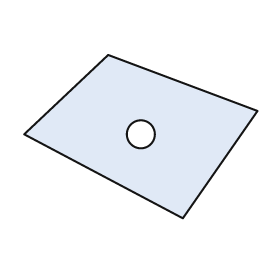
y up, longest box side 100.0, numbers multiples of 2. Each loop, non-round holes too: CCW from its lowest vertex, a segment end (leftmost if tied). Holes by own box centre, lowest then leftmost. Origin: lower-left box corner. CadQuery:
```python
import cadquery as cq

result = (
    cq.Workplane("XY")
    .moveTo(68.0, 0.0)
    .lineTo(100.0, 46.0)
    .lineTo(36.0, 70.0)
    .lineTo(0.0, 36.0)
    .close()
    .moveTo(50.0, 36.0)
    .circle(6.0)
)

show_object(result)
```